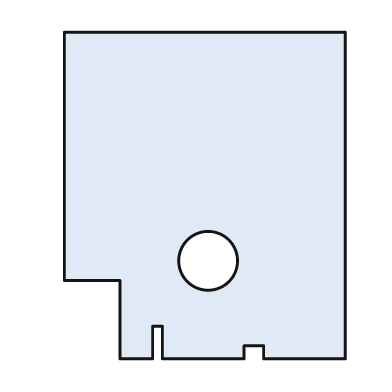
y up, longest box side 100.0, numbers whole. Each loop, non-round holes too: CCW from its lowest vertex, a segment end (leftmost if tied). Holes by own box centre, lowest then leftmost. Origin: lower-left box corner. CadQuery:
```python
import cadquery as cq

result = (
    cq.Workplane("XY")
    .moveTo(17.0, 0.0)
    .lineTo(27.0, 0.0)
    .lineTo(27.0, 10.0)
    .lineTo(30.0, 10.0)
    .lineTo(30.0, 0.0)
    .lineTo(55.0, 0.0)
    .lineTo(55.0, 4.0)
    .lineTo(61.0, 4.0)
    .lineTo(61.0, 0.0)
    .lineTo(86.0, 0.0)
    .lineTo(86.0, 100.0)
    .lineTo(0.0, 100.0)
    .lineTo(0.0, 24.0)
    .lineTo(17.0, 24.0)
    .close()
    .moveTo(44.0, 30.0)
    .circle(9.0)
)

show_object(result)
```